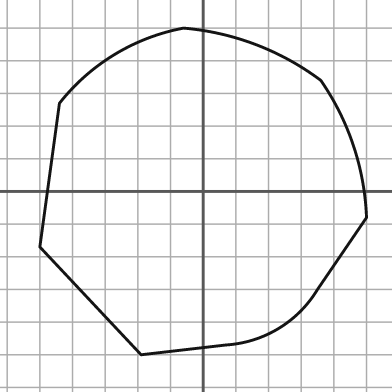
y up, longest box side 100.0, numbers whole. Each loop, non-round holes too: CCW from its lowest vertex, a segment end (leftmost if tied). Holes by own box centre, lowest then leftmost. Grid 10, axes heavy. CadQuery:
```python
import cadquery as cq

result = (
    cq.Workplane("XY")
    .moveTo(-19.0, -50.0)
    .lineTo(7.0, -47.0)
    .threePointArc((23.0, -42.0), (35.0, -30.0))
    .lineTo(50.0, -8.0)
    .threePointArc((46.0, 14.0), (36.0, 34.0))
    .threePointArc((16.0, 45.0), (-6.0, 50.0))
    .threePointArc((-27.0, 42.0), (-44.0, 27.0))
    .lineTo(-50.0, -17.0)
    .close()
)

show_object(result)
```